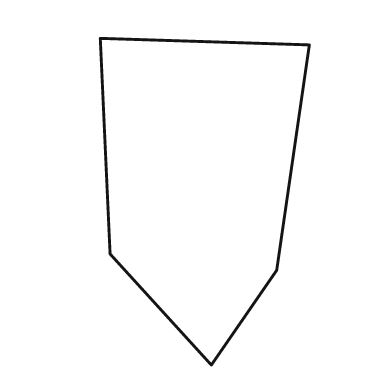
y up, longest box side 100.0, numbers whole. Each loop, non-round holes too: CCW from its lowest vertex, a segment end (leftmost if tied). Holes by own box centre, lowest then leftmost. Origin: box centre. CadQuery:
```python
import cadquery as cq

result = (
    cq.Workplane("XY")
    .moveTo(2.0, -50.0)
    .lineTo(22.0, -21.0)
    .lineTo(32.0, 48.0)
    .lineTo(-32.0, 50.0)
    .lineTo(-29.0, -16.0)
    .close()
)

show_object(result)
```